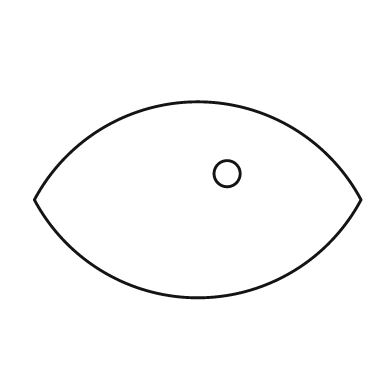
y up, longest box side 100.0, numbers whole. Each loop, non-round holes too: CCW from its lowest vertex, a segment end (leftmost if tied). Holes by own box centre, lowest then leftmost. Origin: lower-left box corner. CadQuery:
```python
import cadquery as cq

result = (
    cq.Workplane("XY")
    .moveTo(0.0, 30.0)
    .threePointArc((50.0, 0.0), (100.0, 30.0))
    .threePointArc((50.0, 60.0), (0.0, 30.0))
    .close()
    .moveTo(59.0, 38.0)
    .circle(4.0)
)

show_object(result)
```